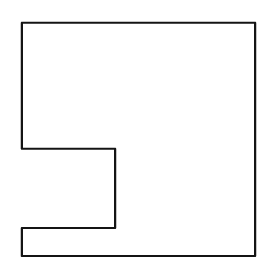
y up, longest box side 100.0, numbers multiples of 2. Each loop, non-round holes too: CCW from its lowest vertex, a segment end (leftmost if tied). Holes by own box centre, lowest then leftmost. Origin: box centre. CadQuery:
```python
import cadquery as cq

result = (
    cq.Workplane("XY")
    .moveTo(-50.0, -50.0)
    .lineTo(50.0, -50.0)
    .lineTo(50.0, 50.0)
    .lineTo(-50.0, 50.0)
    .lineTo(-50.0, -4.0)
    .lineTo(-10.0, -4.0)
    .lineTo(-10.0, -38.0)
    .lineTo(-50.0, -38.0)
    .close()
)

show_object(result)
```